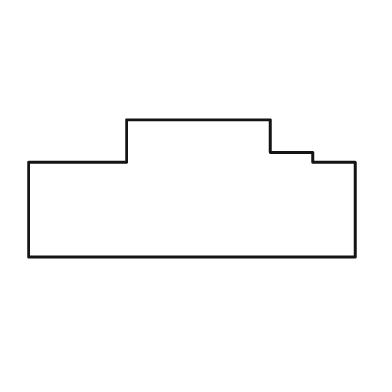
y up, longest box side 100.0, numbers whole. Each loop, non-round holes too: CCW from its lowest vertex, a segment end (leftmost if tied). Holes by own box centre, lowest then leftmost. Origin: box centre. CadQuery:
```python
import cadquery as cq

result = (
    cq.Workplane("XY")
    .moveTo(-50.0, -21.0)
    .lineTo(50.0, -21.0)
    .lineTo(50.0, 8.0)
    .lineTo(37.0, 8.0)
    .lineTo(37.0, 11.0)
    .lineTo(24.0, 11.0)
    .lineTo(24.0, 21.0)
    .lineTo(-20.0, 21.0)
    .lineTo(-20.0, 8.0)
    .lineTo(-50.0, 8.0)
    .close()
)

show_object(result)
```